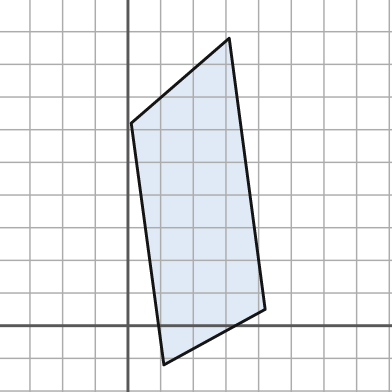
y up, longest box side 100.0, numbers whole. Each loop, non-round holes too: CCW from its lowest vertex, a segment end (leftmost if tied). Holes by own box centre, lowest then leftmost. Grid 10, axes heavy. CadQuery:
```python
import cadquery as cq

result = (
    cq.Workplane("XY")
    .moveTo(11.0, -12.0)
    .lineTo(42.0, 5.0)
    .lineTo(31.0, 88.0)
    .lineTo(1.0, 62.0)
    .close()
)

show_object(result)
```